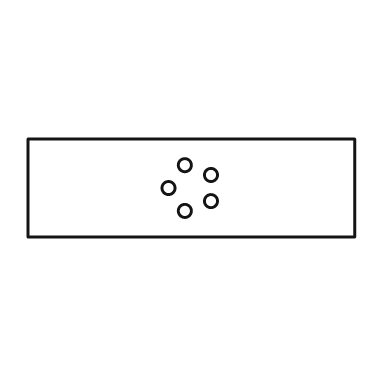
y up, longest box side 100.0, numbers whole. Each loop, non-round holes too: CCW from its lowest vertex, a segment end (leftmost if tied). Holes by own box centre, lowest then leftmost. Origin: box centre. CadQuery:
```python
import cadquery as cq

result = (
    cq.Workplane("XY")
    .moveTo(-50.0, -15.0)
    .lineTo(50.0, -15.0)
    .lineTo(50.0, 15.0)
    .lineTo(-50.0, 15.0)
    .close()
    .moveTo(-2.0, -7.0)
    .circle(2.0)
    .moveTo(6.0, -4.0)
    .circle(2.0)
    .moveTo(-7.0, 0.0)
    .circle(2.0)
    .moveTo(6.0, 4.0)
    .circle(2.0)
    .moveTo(-2.0, 7.0)
    .circle(2.0)
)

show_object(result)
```